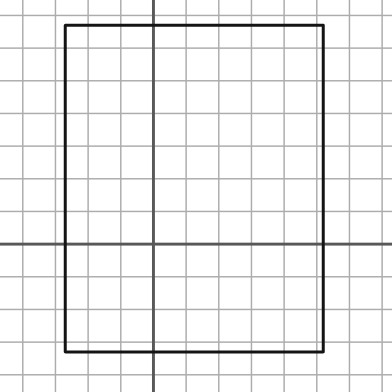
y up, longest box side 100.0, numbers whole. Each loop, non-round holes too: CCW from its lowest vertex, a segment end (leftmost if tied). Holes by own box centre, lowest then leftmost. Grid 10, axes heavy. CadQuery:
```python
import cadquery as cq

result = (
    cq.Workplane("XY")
    .moveTo(-27.0, -33.0)
    .lineTo(52.0, -33.0)
    .lineTo(52.0, 67.0)
    .lineTo(-27.0, 67.0)
    .close()
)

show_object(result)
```